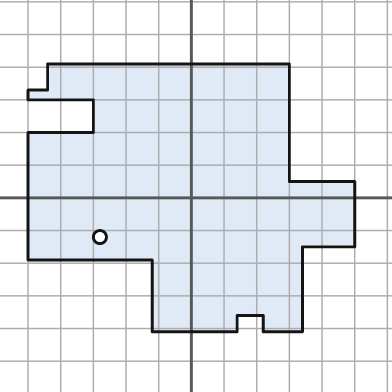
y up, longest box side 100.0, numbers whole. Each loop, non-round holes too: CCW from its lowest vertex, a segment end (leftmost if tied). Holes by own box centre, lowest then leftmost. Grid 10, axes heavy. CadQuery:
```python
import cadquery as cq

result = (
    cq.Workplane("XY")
    .moveTo(-12.0, -41.0)
    .lineTo(14.0, -41.0)
    .lineTo(14.0, -36.0)
    .lineTo(22.0, -36.0)
    .lineTo(22.0, -41.0)
    .lineTo(34.0, -41.0)
    .lineTo(34.0, -15.0)
    .lineTo(50.0, -15.0)
    .lineTo(50.0, 5.0)
    .lineTo(30.0, 5.0)
    .lineTo(30.0, 41.0)
    .lineTo(-44.0, 41.0)
    .lineTo(-44.0, 33.0)
    .lineTo(-50.0, 33.0)
    .lineTo(-50.0, 30.0)
    .lineTo(-30.0, 30.0)
    .lineTo(-30.0, 20.0)
    .lineTo(-50.0, 20.0)
    .lineTo(-50.0, -19.0)
    .lineTo(-12.0, -19.0)
    .close()
    .moveTo(-28.0, -12.0)
    .circle(2.0)
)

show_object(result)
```